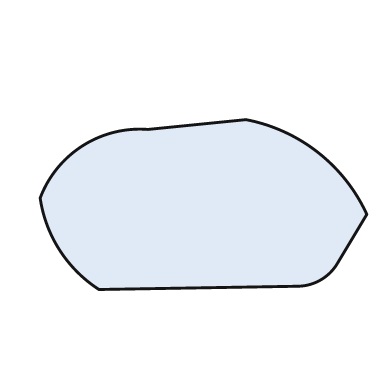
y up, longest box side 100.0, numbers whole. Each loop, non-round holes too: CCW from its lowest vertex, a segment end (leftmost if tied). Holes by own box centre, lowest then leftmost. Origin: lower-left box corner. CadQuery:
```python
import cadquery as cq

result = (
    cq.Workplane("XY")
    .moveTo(18.0, 0.0)
    .lineTo(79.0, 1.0)
    .threePointArc((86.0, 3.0), (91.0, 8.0))
    .lineTo(100.0, 23.0)
    .threePointArc((85.0, 42.0), (63.0, 52.0))
    .lineTo(33.0, 49.0)
    .threePointArc((13.0, 44.0), (0.0, 28.0))
    .threePointArc((6.0, 12.0), (18.0, 0.0))
    .close()
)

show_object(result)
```